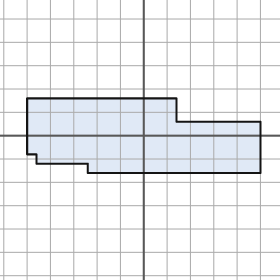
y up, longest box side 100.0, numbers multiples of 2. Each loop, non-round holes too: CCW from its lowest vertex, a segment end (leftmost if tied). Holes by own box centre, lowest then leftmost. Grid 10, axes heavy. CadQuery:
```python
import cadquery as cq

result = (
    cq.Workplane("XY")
    .moveTo(-24.0, -16.0)
    .lineTo(50.0, -16.0)
    .lineTo(50.0, 6.0)
    .lineTo(14.0, 6.0)
    .lineTo(14.0, 16.0)
    .lineTo(-50.0, 16.0)
    .lineTo(-50.0, -8.0)
    .lineTo(-46.0, -8.0)
    .lineTo(-46.0, -12.0)
    .lineTo(-24.0, -12.0)
    .close()
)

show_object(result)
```